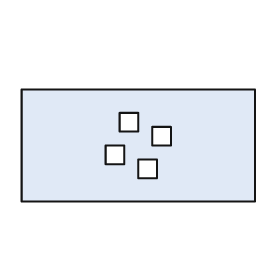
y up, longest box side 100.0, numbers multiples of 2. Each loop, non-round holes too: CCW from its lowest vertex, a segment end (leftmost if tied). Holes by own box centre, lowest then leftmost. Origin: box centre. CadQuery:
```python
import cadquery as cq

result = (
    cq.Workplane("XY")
    .moveTo(-50.0, -24.0)
    .lineTo(50.0, -24.0)
    .lineTo(50.0, 24.0)
    .lineTo(-50.0, 24.0)
    .close()
    .moveTo(0.0, -14.0)
    .lineTo(8.0, -14.0)
    .lineTo(8.0, -6.0)
    .lineTo(0.0, -6.0)
    .close()
    .moveTo(-14.0, -8.0)
    .lineTo(-6.0, -8.0)
    .lineTo(-6.0, 0.0)
    .lineTo(-14.0, 0.0)
    .close()
    .moveTo(6.0, 0.0)
    .lineTo(14.0, 0.0)
    .lineTo(14.0, 8.0)
    .lineTo(6.0, 8.0)
    .close()
    .moveTo(-8.0, 6.0)
    .lineTo(0.0, 6.0)
    .lineTo(0.0, 14.0)
    .lineTo(-8.0, 14.0)
    .close()
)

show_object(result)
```